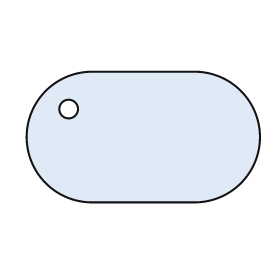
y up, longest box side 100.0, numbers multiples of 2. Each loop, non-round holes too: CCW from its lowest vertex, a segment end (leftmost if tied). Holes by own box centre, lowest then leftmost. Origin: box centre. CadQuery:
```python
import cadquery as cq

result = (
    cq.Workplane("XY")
    .moveTo(-22.0, -28.0)
    .lineTo(22.0, -28.0)
    .threePointArc((50.0, 0.0), (22.0, 28.0))
    .lineTo(-22.0, 28.0)
    .threePointArc((-50.0, 0.0), (-22.0, -28.0))
    .close()
    .moveTo(-32.0, 12.0)
    .circle(4.0)
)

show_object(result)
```